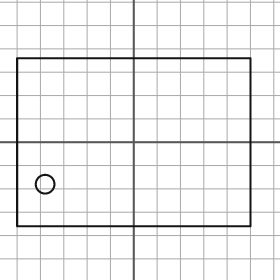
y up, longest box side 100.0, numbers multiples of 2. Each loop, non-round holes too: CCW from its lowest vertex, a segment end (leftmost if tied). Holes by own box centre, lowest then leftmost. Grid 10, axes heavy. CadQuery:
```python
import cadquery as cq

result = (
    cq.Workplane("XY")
    .moveTo(-50.0, -36.0)
    .lineTo(50.0, -36.0)
    .lineTo(50.0, 36.0)
    .lineTo(-50.0, 36.0)
    .close()
    .moveTo(-38.0, -18.0)
    .circle(4.0)
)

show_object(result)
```